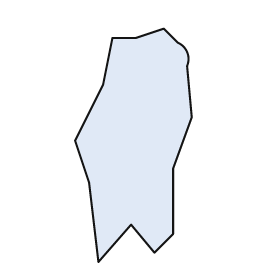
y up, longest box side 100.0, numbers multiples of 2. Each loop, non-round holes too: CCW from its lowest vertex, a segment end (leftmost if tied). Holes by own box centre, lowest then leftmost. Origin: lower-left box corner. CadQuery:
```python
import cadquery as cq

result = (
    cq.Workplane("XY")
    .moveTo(10.0, 0.0)
    .lineTo(24.0, 16.0)
    .lineTo(34.0, 4.0)
    .lineTo(42.0, 12.0)
    .lineTo(42.0, 40.0)
    .lineTo(50.0, 62.0)
    .lineTo(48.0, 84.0)
    .threePointArc((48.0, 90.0), (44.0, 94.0))
    .lineTo(38.0, 100.0)
    .lineTo(26.0, 96.0)
    .lineTo(16.0, 96.0)
    .lineTo(12.0, 76.0)
    .lineTo(0.0, 52.0)
    .lineTo(6.0, 34.0)
    .close()
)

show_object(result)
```